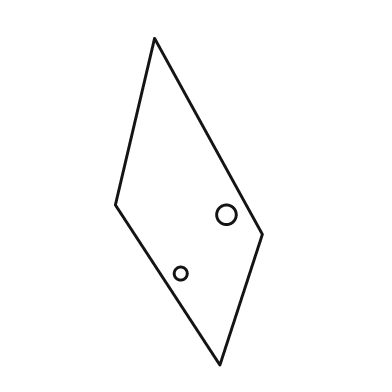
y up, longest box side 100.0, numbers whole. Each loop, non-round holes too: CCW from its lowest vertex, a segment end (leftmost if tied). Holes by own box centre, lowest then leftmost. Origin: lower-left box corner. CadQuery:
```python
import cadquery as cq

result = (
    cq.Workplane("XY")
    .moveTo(32.0, 0.0)
    .lineTo(45.0, 40.0)
    .lineTo(12.0, 100.0)
    .lineTo(0.0, 49.0)
    .close()
    .moveTo(20.0, 28.0)
    .circle(2.0)
    .moveTo(34.0, 46.0)
    .circle(3.0)
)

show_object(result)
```